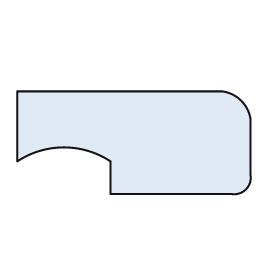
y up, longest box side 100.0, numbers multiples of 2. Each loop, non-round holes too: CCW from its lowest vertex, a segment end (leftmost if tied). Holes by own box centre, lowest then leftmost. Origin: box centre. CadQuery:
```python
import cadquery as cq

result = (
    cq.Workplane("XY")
    .moveTo(-10.0, -22.0)
    .lineTo(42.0, -22.0)
    .threePointArc((48.0, -20.0), (50.0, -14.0))
    .lineTo(50.0, 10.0)
    .threePointArc((46.0, 18.0), (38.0, 22.0))
    .lineTo(-50.0, 22.0)
    .lineTo(-50.0, -8.0)
    .threePointArc((-30.0, -2.0), (-10.0, -8.0))
    .close()
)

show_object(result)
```